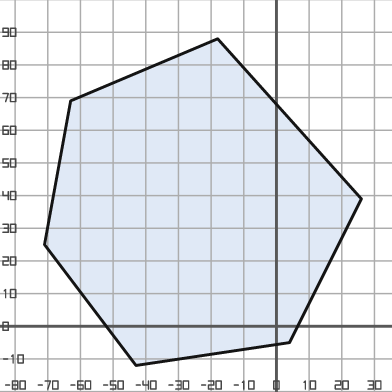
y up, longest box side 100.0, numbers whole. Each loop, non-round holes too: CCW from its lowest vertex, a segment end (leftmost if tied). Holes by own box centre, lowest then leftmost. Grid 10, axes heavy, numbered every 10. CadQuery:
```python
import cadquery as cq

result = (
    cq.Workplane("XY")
    .moveTo(-43.0, -12.0)
    .lineTo(4.0, -5.0)
    .lineTo(26.0, 39.0)
    .lineTo(-18.0, 88.0)
    .lineTo(-63.0, 69.0)
    .lineTo(-71.0, 25.0)
    .close()
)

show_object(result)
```